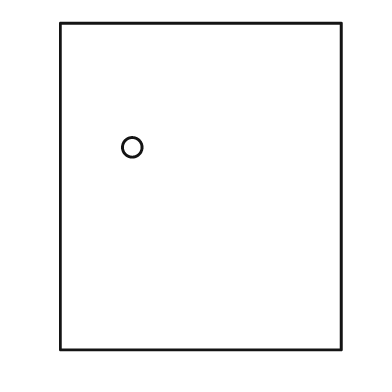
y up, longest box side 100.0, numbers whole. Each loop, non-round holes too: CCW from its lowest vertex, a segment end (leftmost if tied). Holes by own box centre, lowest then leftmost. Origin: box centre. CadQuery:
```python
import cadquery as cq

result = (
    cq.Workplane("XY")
    .moveTo(-43.0, -50.0)
    .lineTo(43.0, -50.0)
    .lineTo(43.0, 50.0)
    .lineTo(-43.0, 50.0)
    .close()
    .moveTo(-21.0, 12.0)
    .circle(3.0)
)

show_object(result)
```